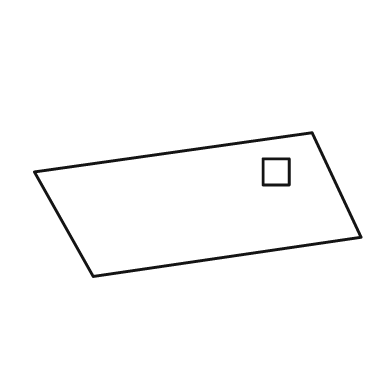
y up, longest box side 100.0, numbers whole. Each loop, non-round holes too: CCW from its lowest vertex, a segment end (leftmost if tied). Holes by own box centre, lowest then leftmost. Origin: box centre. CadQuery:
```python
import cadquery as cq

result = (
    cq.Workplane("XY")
    .moveTo(-32.0, -22.0)
    .lineTo(50.0, -10.0)
    .lineTo(35.0, 22.0)
    .lineTo(-50.0, 10.0)
    .close()
    .moveTo(20.0, 6.0)
    .lineTo(28.0, 6.0)
    .lineTo(28.0, 14.0)
    .lineTo(20.0, 14.0)
    .close()
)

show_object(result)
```